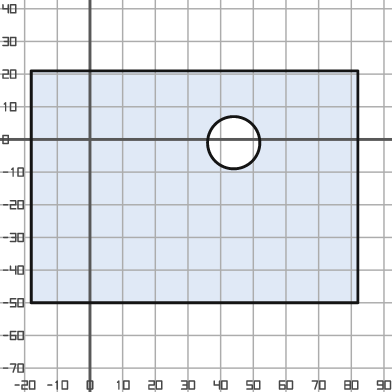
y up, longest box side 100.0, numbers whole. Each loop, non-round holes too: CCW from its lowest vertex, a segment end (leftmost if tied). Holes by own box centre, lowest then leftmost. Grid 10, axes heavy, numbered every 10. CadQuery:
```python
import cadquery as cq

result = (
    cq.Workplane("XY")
    .moveTo(-18.0, -50.0)
    .lineTo(82.0, -50.0)
    .lineTo(82.0, 21.0)
    .lineTo(-18.0, 21.0)
    .close()
    .moveTo(44.0, -1.0)
    .circle(8.0)
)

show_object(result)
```